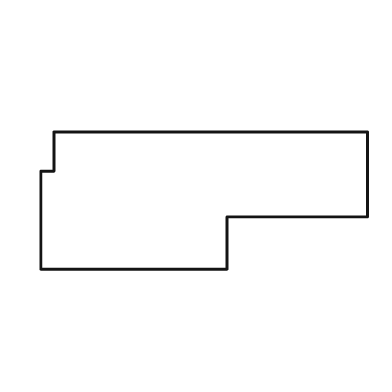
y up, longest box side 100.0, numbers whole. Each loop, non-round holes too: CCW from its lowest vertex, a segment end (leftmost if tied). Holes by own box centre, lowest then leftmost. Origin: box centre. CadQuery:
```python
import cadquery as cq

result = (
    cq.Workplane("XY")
    .moveTo(-50.0, -21.0)
    .lineTo(7.0, -21.0)
    .lineTo(7.0, -5.0)
    .lineTo(50.0, -5.0)
    .lineTo(50.0, 21.0)
    .lineTo(-46.0, 21.0)
    .lineTo(-46.0, 9.0)
    .lineTo(-50.0, 9.0)
    .close()
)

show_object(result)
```